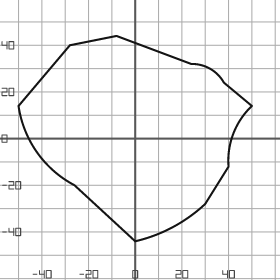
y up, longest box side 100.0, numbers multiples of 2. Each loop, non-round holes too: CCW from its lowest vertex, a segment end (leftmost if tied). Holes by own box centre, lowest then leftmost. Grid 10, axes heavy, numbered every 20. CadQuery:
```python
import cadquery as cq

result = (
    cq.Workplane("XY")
    .moveTo(0.0, -44.0)
    .threePointArc((16.0, -38.0), (30.0, -28.0))
    .lineTo(40.0, -12.0)
    .threePointArc((42.0, 2.0), (50.0, 14.0))
    .lineTo(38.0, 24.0)
    .threePointArc((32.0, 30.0), (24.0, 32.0))
    .lineTo(-8.0, 44.0)
    .lineTo(-28.0, 40.0)
    .lineTo(-50.0, 14.0)
    .threePointArc((-42.0, -6.0), (-26.0, -20.0))
    .close()
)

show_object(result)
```